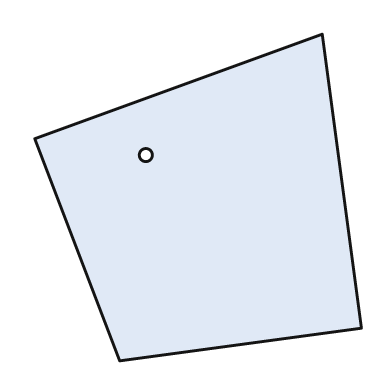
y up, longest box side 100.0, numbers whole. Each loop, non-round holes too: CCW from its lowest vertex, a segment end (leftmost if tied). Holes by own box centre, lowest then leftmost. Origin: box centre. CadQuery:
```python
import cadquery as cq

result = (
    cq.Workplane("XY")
    .moveTo(-24.0, -50.0)
    .lineTo(50.0, -40.0)
    .lineTo(38.0, 50.0)
    .lineTo(-50.0, 18.0)
    .close()
    .moveTo(-16.0, 13.0)
    .circle(2.0)
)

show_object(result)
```